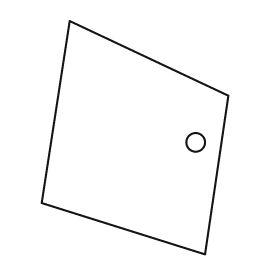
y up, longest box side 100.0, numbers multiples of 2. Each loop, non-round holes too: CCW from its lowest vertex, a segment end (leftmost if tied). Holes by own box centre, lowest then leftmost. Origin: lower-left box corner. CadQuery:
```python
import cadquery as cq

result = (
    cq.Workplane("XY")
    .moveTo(70.0, 0.0)
    .lineTo(80.0, 68.0)
    .lineTo(12.0, 100.0)
    .lineTo(0.0, 22.0)
    .close()
    .moveTo(66.0, 48.0)
    .circle(4.0)
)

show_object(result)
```